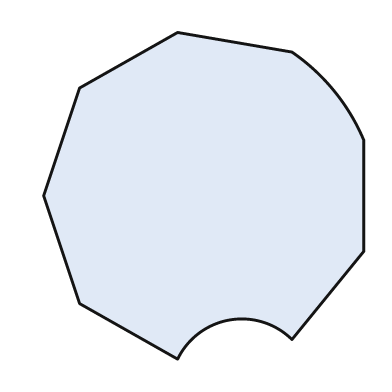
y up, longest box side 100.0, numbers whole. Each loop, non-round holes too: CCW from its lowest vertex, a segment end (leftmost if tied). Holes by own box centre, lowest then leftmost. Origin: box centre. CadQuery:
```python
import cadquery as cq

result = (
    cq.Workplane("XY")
    .moveTo(-8.0, -50.0)
    .threePointArc((8.0, -38.0), (27.0, -44.0))
    .lineTo(49.0, -17.0)
    .lineTo(49.0, 17.0)
    .threePointArc((40.0, 32.0), (27.0, 44.0))
    .lineTo(-8.0, 50.0)
    .lineTo(-38.0, 33.0)
    .lineTo(-49.0, 0.0)
    .lineTo(-38.0, -33.0)
    .close()
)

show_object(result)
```